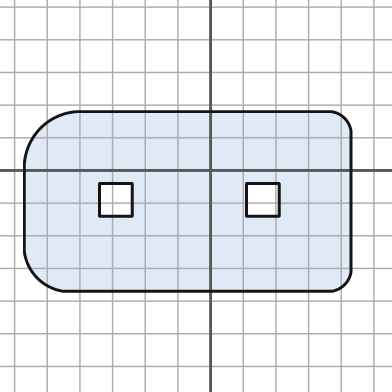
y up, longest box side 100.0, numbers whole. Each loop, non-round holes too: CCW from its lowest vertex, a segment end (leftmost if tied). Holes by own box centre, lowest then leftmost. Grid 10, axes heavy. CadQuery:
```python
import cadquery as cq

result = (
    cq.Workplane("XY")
    .moveTo(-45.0, -37.0)
    .lineTo(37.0, -37.0)
    .threePointArc((41.0, -35.0), (43.0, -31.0))
    .lineTo(43.0, 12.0)
    .threePointArc((41.0, 16.0), (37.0, 18.0))
    .lineTo(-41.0, 18.0)
    .threePointArc((-52.0, 13.0), (-57.0, 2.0))
    .lineTo(-57.0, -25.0)
    .threePointArc((-53.0, -33.0), (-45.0, -37.0))
    .close()
    .moveTo(-34.0, -14.0)
    .lineTo(-24.0, -14.0)
    .lineTo(-24.0, -4.0)
    .lineTo(-34.0, -4.0)
    .close()
    .moveTo(11.0, -14.0)
    .lineTo(21.0, -14.0)
    .lineTo(21.0, -4.0)
    .lineTo(11.0, -4.0)
    .close()
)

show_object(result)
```